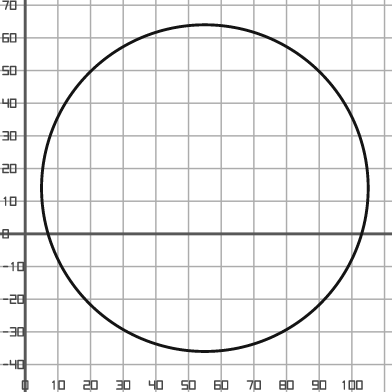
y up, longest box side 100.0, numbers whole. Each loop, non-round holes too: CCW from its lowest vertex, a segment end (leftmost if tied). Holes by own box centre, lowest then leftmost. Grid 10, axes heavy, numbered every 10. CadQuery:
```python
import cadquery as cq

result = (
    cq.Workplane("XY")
    .moveTo(55.0, 14.0)
    .circle(50.0)
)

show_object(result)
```